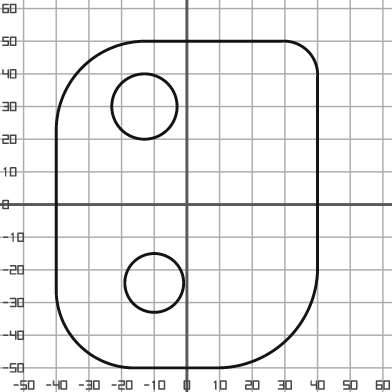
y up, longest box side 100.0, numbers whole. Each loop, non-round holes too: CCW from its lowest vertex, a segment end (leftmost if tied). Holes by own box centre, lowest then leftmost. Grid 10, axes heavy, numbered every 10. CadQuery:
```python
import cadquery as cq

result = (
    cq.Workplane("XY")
    .moveTo(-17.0, -50.0)
    .lineTo(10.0, -50.0)
    .threePointArc((31.0, -41.0), (40.0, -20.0))
    .lineTo(40.0, 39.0)
    .threePointArc((37.0, 47.0), (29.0, 50.0))
    .lineTo(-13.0, 50.0)
    .threePointArc((-32.0, 42.0), (-40.0, 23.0))
    .lineTo(-40.0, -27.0)
    .threePointArc((-33.0, -43.0), (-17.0, -50.0))
    .close()
    .moveTo(-10.0, -24.0)
    .circle(9.0)
    .moveTo(-13.0, 30.0)
    .circle(10.0)
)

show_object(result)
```